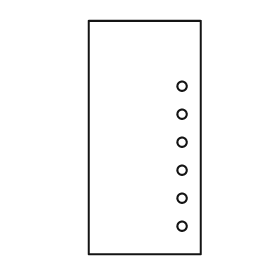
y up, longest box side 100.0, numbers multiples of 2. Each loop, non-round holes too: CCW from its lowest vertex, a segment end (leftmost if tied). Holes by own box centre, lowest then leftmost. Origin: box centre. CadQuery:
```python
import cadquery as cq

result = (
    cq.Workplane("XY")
    .moveTo(-24.0, -50.0)
    .lineTo(24.0, -50.0)
    .lineTo(24.0, 50.0)
    .lineTo(-24.0, 50.0)
    .close()
    .moveTo(16.0, -38.0)
    .circle(2.0)
    .moveTo(16.0, -26.0)
    .circle(2.0)
    .moveTo(16.0, -14.0)
    .circle(2.0)
    .moveTo(16.0, -2.0)
    .circle(2.0)
    .moveTo(16.0, 10.0)
    .circle(2.0)
    .moveTo(16.0, 22.0)
    .circle(2.0)
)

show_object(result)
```